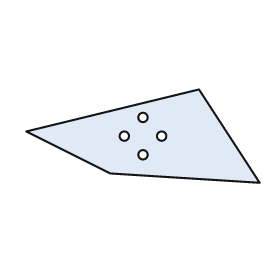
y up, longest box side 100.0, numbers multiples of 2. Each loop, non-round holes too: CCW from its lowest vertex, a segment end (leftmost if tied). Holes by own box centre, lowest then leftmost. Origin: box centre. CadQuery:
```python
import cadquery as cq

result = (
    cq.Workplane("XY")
    .moveTo(50.0, -20.0)
    .lineTo(24.0, 20.0)
    .lineTo(-50.0, 2.0)
    .lineTo(-14.0, -16.0)
    .close()
    .moveTo(0.0, -8.0)
    .circle(2.0)
    .moveTo(-8.0, 0.0)
    .circle(2.0)
    .moveTo(8.0, 0.0)
    .circle(2.0)
    .moveTo(0.0, 8.0)
    .circle(2.0)
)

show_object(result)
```